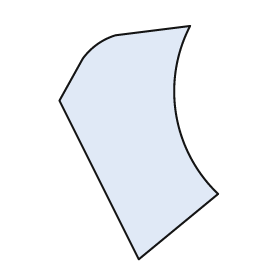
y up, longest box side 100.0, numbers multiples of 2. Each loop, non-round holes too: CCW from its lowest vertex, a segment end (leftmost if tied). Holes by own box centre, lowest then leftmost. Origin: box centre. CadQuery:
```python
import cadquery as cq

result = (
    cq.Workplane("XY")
    .moveTo(0.0, -50.0)
    .lineTo(34.0, -22.0)
    .threePointArc((16.0, 12.0), (22.0, 50.0))
    .lineTo(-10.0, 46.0)
    .threePointArc((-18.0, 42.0), (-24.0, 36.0))
    .lineTo(-34.0, 18.0)
    .close()
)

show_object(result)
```